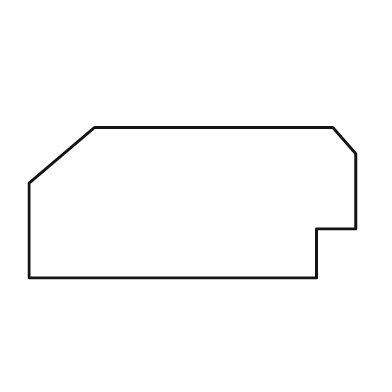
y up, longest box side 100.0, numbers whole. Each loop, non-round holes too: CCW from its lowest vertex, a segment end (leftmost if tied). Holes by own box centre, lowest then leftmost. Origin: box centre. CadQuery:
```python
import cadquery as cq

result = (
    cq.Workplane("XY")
    .moveTo(-50.0, -23.0)
    .lineTo(38.0, -23.0)
    .lineTo(38.0, -8.0)
    .lineTo(50.0, -8.0)
    .lineTo(50.0, 15.0)
    .lineTo(43.0, 23.0)
    .lineTo(-30.0, 23.0)
    .lineTo(-50.0, 6.0)
    .close()
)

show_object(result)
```